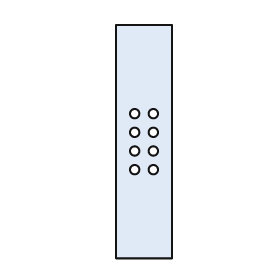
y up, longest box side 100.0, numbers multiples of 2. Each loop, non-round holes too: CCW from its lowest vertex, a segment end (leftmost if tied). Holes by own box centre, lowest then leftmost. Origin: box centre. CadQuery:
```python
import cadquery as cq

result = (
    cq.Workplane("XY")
    .moveTo(-12.0, -50.0)
    .lineTo(12.0, -50.0)
    .lineTo(12.0, 50.0)
    .lineTo(-12.0, 50.0)
    .close()
    .moveTo(-4.0, -12.0)
    .circle(2.0)
    .moveTo(4.0, -12.0)
    .circle(2.0)
    .moveTo(-4.0, -4.0)
    .circle(2.0)
    .moveTo(4.0, -4.0)
    .circle(2.0)
    .moveTo(-4.0, 4.0)
    .circle(2.0)
    .moveTo(4.0, 4.0)
    .circle(2.0)
    .moveTo(-4.0, 12.0)
    .circle(2.0)
    .moveTo(4.0, 12.0)
    .circle(2.0)
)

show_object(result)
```